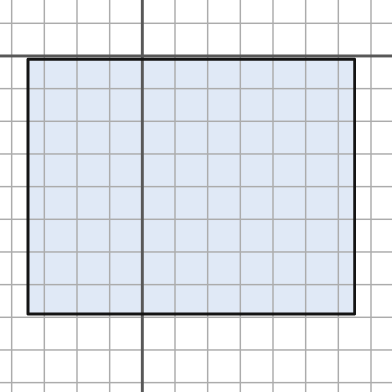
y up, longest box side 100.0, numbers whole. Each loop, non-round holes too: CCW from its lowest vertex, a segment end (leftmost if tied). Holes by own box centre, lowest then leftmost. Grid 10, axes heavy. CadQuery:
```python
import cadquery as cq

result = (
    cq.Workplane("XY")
    .moveTo(-35.0, -79.0)
    .lineTo(65.0, -79.0)
    .lineTo(65.0, -1.0)
    .lineTo(-35.0, -1.0)
    .close()
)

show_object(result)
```